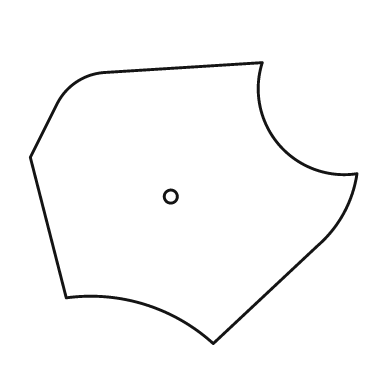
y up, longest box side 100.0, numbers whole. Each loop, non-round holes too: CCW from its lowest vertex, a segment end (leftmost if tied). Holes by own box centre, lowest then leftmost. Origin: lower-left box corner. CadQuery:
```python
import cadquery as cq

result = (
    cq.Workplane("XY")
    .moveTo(56.0, 0.0)
    .lineTo(88.0, 30.0)
    .threePointArc((96.0, 40.0), (100.0, 52.0))
    .threePointArc((76.0, 61.0), (71.0, 86.0))
    .lineTo(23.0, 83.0)
    .threePointArc((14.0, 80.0), (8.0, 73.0))
    .lineTo(0.0, 57.0)
    .lineTo(11.0, 14.0)
    .threePointArc((35.0, 12.0), (56.0, 0.0))
    .close()
    .moveTo(43.0, 45.0)
    .circle(2.0)
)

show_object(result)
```